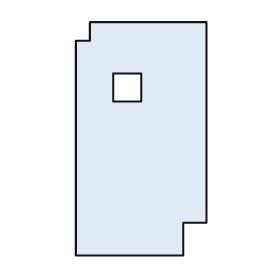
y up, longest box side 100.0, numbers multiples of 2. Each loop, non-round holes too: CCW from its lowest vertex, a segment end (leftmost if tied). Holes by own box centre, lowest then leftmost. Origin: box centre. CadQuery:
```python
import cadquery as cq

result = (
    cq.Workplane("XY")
    .moveTo(-28.0, -50.0)
    .lineTo(18.0, -50.0)
    .lineTo(18.0, -36.0)
    .lineTo(28.0, -36.0)
    .lineTo(28.0, 50.0)
    .lineTo(-22.0, 50.0)
    .lineTo(-22.0, 42.0)
    .lineTo(-28.0, 42.0)
    .close()
    .moveTo(-12.0, 16.0)
    .lineTo(0.0, 16.0)
    .lineTo(0.0, 28.0)
    .lineTo(-12.0, 28.0)
    .close()
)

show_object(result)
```